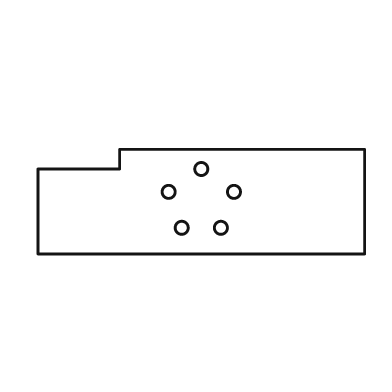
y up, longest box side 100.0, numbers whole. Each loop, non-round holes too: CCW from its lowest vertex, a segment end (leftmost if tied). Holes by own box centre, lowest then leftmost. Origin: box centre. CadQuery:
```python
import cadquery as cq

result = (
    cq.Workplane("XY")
    .moveTo(-50.0, -16.0)
    .lineTo(50.0, -16.0)
    .lineTo(50.0, 16.0)
    .lineTo(-25.0, 16.0)
    .lineTo(-25.0, 10.0)
    .lineTo(-50.0, 10.0)
    .close()
    .moveTo(-6.0, -8.0)
    .circle(2.0)
    .moveTo(6.0, -8.0)
    .circle(2.0)
    .moveTo(-10.0, 3.0)
    .circle(2.0)
    .moveTo(10.0, 3.0)
    .circle(2.0)
    .moveTo(0.0, 10.0)
    .circle(2.0)
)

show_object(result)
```